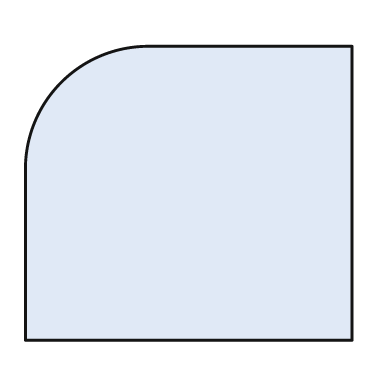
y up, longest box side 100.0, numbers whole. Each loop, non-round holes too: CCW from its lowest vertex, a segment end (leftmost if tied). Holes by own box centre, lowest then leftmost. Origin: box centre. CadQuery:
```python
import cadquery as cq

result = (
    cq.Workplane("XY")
    .moveTo(-50.0, -45.0)
    .lineTo(50.0, -45.0)
    .lineTo(50.0, 45.0)
    .lineTo(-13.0, 45.0)
    .threePointArc((-39.0, 34.0), (-50.0, 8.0))
    .close()
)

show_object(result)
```